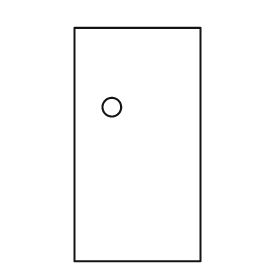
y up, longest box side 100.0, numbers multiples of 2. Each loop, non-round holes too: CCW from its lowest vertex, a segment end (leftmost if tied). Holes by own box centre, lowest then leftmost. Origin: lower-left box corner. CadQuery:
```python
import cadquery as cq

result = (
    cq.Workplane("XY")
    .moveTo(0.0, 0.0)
    .lineTo(54.0, 0.0)
    .lineTo(54.0, 100.0)
    .lineTo(0.0, 100.0)
    .close()
    .moveTo(16.0, 66.0)
    .circle(4.0)
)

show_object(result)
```